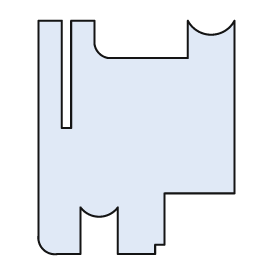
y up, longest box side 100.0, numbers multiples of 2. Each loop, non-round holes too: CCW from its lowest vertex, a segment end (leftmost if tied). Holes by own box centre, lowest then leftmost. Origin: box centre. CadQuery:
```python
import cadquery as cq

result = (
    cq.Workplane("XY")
    .moveTo(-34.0, -50.0)
    .lineTo(-24.0, -50.0)
    .lineTo(-24.0, -30.0)
    .threePointArc((-16.0, -34.0), (-8.0, -30.0))
    .lineTo(-8.0, -50.0)
    .lineTo(8.0, -50.0)
    .lineTo(8.0, -46.0)
    .lineTo(12.0, -46.0)
    .lineTo(12.0, -24.0)
    .lineTo(42.0, -24.0)
    .lineTo(42.0, 50.0)
    .threePointArc((32.0, 44.0), (22.0, 50.0))
    .lineTo(22.0, 34.0)
    .lineTo(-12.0, 34.0)
    .threePointArc((-16.0, 36.0), (-18.0, 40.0))
    .lineTo(-18.0, 50.0)
    .lineTo(-28.0, 50.0)
    .lineTo(-28.0, 4.0)
    .lineTo(-32.0, 4.0)
    .lineTo(-32.0, 50.0)
    .lineTo(-42.0, 50.0)
    .lineTo(-42.0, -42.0)
    .threePointArc((-40.0, -48.0), (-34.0, -50.0))
    .close()
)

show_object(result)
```